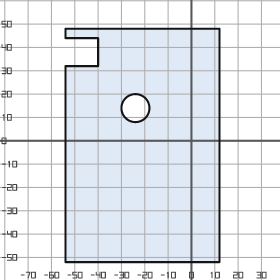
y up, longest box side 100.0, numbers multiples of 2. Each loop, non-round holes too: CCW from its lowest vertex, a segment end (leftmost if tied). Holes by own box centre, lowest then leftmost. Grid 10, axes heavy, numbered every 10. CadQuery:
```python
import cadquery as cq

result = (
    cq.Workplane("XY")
    .moveTo(-54.0, -52.0)
    .lineTo(12.0, -52.0)
    .lineTo(12.0, 48.0)
    .lineTo(-54.0, 48.0)
    .lineTo(-54.0, 44.0)
    .lineTo(-40.0, 44.0)
    .lineTo(-40.0, 32.0)
    .lineTo(-54.0, 32.0)
    .close()
    .moveTo(-24.0, 14.0)
    .circle(6.0)
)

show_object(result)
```